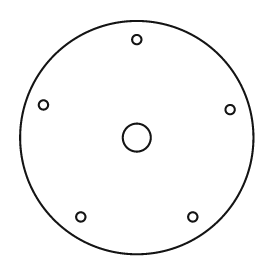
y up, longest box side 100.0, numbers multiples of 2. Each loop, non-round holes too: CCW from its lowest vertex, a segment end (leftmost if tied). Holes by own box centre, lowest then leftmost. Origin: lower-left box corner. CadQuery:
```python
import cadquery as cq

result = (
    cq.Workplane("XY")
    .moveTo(50.0, 50.0)
    .circle(50.0)
    .moveTo(26.0, 16.0)
    .circle(2.0)
    .moveTo(74.0, 16.0)
    .circle(2.0)
    .moveTo(50.0, 50.0)
    .circle(6.0)
    .moveTo(90.0, 62.0)
    .circle(2.0)
    .moveTo(10.0, 64.0)
    .circle(2.0)
    .moveTo(50.0, 92.0)
    .circle(2.0)
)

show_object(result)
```